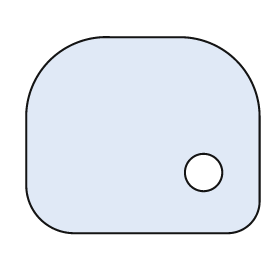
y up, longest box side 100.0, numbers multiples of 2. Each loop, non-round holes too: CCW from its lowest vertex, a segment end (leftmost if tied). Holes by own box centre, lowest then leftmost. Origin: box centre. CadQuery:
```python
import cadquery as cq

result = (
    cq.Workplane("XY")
    .moveTo(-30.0, -42.0)
    .lineTo(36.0, -42.0)
    .threePointArc((46.0, -38.0), (50.0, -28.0))
    .lineTo(50.0, 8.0)
    .threePointArc((40.0, 32.0), (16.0, 42.0))
    .lineTo(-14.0, 42.0)
    .threePointArc((-40.0, 32.0), (-50.0, 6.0))
    .lineTo(-50.0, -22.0)
    .threePointArc((-44.0, -36.0), (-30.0, -42.0))
    .close()
    .moveTo(26.0, -16.0)
    .circle(8.0)
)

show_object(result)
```